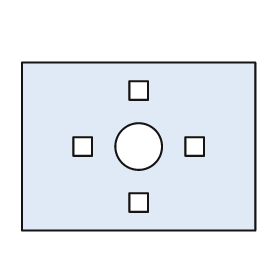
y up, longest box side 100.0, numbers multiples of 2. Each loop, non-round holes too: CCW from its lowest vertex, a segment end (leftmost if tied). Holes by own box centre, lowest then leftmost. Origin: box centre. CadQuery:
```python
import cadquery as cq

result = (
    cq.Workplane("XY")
    .moveTo(-50.0, -36.0)
    .lineTo(50.0, -36.0)
    .lineTo(50.0, 36.0)
    .lineTo(-50.0, 36.0)
    .close()
    .moveTo(-4.0, -28.0)
    .lineTo(4.0, -28.0)
    .lineTo(4.0, -20.0)
    .lineTo(-4.0, -20.0)
    .close()
    .moveTo(-28.0, -4.0)
    .lineTo(-20.0, -4.0)
    .lineTo(-20.0, 4.0)
    .lineTo(-28.0, 4.0)
    .close()
    .moveTo(0.0, 0.0)
    .circle(10.0)
    .moveTo(20.0, -4.0)
    .lineTo(28.0, -4.0)
    .lineTo(28.0, 4.0)
    .lineTo(20.0, 4.0)
    .close()
    .moveTo(-4.0, 20.0)
    .lineTo(4.0, 20.0)
    .lineTo(4.0, 28.0)
    .lineTo(-4.0, 28.0)
    .close()
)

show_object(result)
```